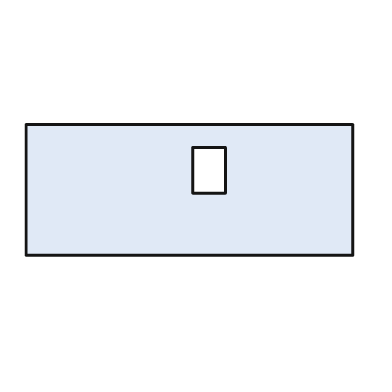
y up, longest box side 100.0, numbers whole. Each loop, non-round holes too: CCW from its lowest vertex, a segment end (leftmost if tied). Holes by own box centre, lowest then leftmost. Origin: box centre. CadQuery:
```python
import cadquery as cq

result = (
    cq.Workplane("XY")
    .moveTo(-50.0, -20.0)
    .lineTo(50.0, -20.0)
    .lineTo(50.0, 20.0)
    .lineTo(-50.0, 20.0)
    .close()
    .moveTo(1.0, -1.0)
    .lineTo(11.0, -1.0)
    .lineTo(11.0, 13.0)
    .lineTo(1.0, 13.0)
    .close()
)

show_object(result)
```